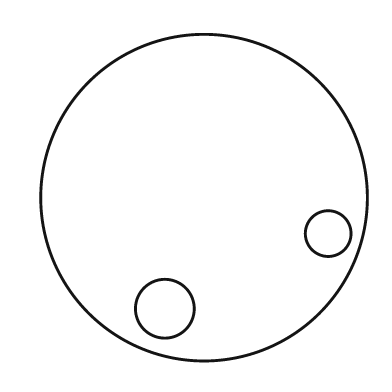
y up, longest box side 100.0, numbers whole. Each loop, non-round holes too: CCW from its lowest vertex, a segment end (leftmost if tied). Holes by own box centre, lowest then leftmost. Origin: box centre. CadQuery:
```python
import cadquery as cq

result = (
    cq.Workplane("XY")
    .moveTo(0.0, 0.0)
    .circle(50.0)
    .moveTo(-12.0, -34.0)
    .circle(9.0)
    .moveTo(38.0, -11.0)
    .circle(7.0)
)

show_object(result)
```